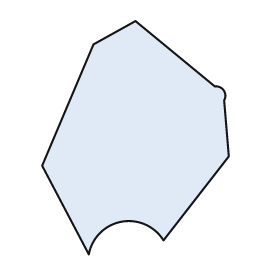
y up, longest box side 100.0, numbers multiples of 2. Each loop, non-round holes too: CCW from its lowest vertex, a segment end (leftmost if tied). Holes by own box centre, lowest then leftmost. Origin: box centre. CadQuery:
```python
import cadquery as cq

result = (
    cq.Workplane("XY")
    .moveTo(-20.0, -50.0)
    .threePointArc((-6.0, -36.0), (12.0, -44.0))
    .lineTo(40.0, -8.0)
    .lineTo(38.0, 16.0)
    .threePointArc((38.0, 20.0), (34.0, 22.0))
    .lineTo(0.0, 50.0)
    .lineTo(-18.0, 40.0)
    .lineTo(-40.0, -12.0)
    .close()
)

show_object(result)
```